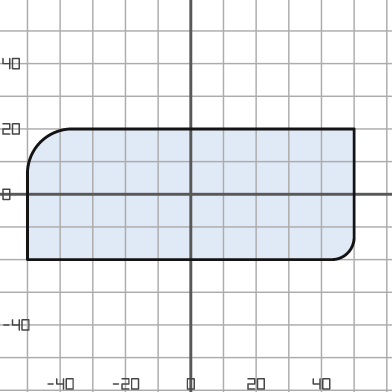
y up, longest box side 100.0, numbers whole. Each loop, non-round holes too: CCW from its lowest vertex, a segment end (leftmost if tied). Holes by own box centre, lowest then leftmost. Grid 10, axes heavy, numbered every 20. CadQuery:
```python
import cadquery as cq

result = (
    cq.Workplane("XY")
    .moveTo(-50.0, -20.0)
    .lineTo(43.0, -20.0)
    .threePointArc((48.0, -18.0), (50.0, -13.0))
    .lineTo(50.0, 20.0)
    .lineTo(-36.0, 20.0)
    .threePointArc((-46.0, 16.0), (-50.0, 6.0))
    .close()
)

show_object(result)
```